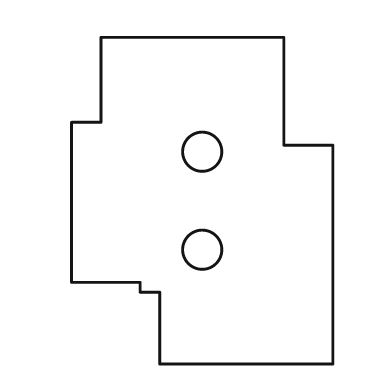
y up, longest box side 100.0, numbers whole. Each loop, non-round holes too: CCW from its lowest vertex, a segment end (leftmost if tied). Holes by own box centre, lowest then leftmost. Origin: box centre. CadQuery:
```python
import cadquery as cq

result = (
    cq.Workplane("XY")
    .moveTo(-13.0, -50.0)
    .lineTo(40.0, -50.0)
    .lineTo(40.0, 17.0)
    .lineTo(25.0, 17.0)
    .lineTo(25.0, 50.0)
    .lineTo(-31.0, 50.0)
    .lineTo(-31.0, 24.0)
    .lineTo(-40.0, 24.0)
    .lineTo(-40.0, -25.0)
    .lineTo(-19.0, -25.0)
    .lineTo(-19.0, -28.0)
    .lineTo(-13.0, -28.0)
    .close()
    .moveTo(0.0, -15.0)
    .circle(6.0)
    .moveTo(0.0, 15.0)
    .circle(6.0)
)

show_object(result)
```